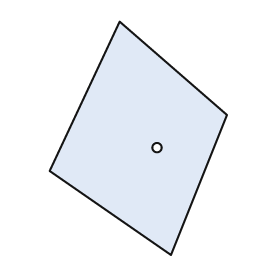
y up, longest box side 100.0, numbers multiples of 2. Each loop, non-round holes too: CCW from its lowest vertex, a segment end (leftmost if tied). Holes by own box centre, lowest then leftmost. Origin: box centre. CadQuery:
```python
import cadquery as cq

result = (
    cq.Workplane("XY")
    .moveTo(14.0, -50.0)
    .lineTo(38.0, 10.0)
    .lineTo(-8.0, 50.0)
    .lineTo(-38.0, -14.0)
    .close()
    .moveTo(8.0, -4.0)
    .circle(2.0)
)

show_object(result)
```